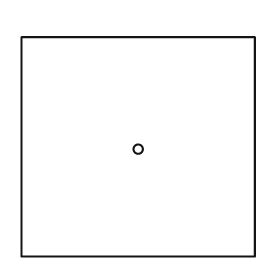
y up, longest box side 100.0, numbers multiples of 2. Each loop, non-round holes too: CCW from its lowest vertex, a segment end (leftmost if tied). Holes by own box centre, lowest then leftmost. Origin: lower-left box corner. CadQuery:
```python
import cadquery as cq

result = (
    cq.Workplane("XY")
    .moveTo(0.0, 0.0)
    .lineTo(100.0, 0.0)
    .lineTo(100.0, 94.0)
    .lineTo(0.0, 94.0)
    .close()
    .moveTo(50.0, 46.0)
    .circle(2.0)
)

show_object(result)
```